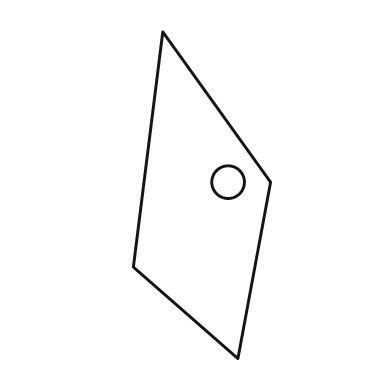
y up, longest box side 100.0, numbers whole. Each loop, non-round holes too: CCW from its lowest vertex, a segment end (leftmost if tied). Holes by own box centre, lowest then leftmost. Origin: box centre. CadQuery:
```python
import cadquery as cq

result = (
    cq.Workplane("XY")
    .moveTo(11.0, -50.0)
    .lineTo(21.0, 4.0)
    .lineTo(-12.0, 50.0)
    .lineTo(-21.0, -22.0)
    .close()
    .moveTo(8.0, 4.0)
    .circle(5.0)
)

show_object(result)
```